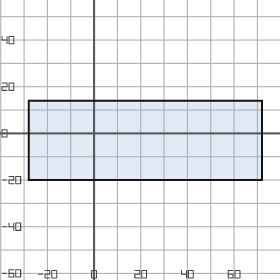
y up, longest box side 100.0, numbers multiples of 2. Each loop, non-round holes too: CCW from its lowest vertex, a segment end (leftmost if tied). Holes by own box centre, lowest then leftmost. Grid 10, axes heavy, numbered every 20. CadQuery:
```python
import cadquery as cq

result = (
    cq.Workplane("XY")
    .moveTo(-28.0, -20.0)
    .lineTo(72.0, -20.0)
    .lineTo(72.0, 14.0)
    .lineTo(-28.0, 14.0)
    .close()
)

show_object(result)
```